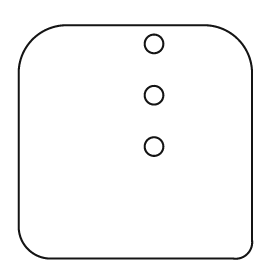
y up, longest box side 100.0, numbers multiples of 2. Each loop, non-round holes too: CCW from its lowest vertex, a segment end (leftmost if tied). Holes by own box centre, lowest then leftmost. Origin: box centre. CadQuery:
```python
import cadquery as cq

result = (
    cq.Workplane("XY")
    .moveTo(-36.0, -50.0)
    .lineTo(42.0, -50.0)
    .threePointArc((48.0, -48.0), (50.0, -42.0))
    .lineTo(50.0, 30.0)
    .threePointArc((44.0, 44.0), (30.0, 50.0))
    .lineTo(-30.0, 50.0)
    .threePointArc((-44.0, 44.0), (-50.0, 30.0))
    .lineTo(-50.0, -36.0)
    .threePointArc((-46.0, -46.0), (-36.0, -50.0))
    .close()
    .moveTo(8.0, -2.0)
    .circle(4.0)
    .moveTo(8.0, 20.0)
    .circle(4.0)
    .moveTo(8.0, 42.0)
    .circle(4.0)
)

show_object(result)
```